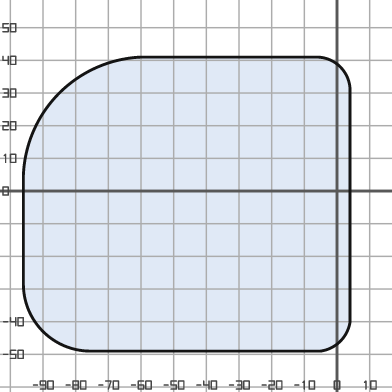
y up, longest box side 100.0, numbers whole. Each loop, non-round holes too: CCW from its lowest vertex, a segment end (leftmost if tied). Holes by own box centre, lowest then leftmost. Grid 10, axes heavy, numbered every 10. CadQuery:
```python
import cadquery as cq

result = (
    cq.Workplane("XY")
    .moveTo(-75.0, -49.0)
    .lineTo(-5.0, -49.0)
    .threePointArc((1.0, -46.0), (4.0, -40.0))
    .lineTo(4.0, 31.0)
    .threePointArc((1.0, 38.0), (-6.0, 41.0))
    .lineTo(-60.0, 41.0)
    .threePointArc((-85.0, 30.0), (-96.0, 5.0))
    .lineTo(-96.0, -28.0)
    .threePointArc((-90.0, -43.0), (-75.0, -49.0))
    .close()
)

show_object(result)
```